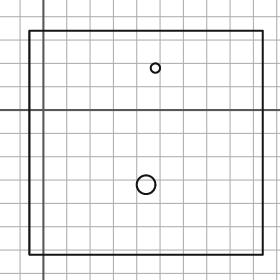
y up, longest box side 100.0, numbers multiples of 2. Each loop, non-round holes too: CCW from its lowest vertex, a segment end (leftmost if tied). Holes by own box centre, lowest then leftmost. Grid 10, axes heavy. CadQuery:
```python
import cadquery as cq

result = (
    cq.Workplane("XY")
    .moveTo(-6.0, -62.0)
    .lineTo(94.0, -62.0)
    .lineTo(94.0, 34.0)
    .lineTo(-6.0, 34.0)
    .close()
    .moveTo(44.0, -32.0)
    .circle(4.0)
    .moveTo(48.0, 18.0)
    .circle(2.0)
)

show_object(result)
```